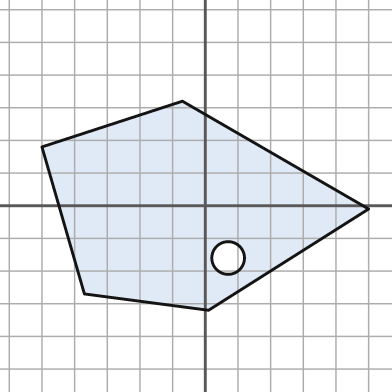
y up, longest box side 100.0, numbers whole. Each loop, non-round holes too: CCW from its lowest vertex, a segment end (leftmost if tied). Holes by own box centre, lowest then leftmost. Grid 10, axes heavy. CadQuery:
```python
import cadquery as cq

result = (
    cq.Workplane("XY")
    .moveTo(1.0, -32.0)
    .lineTo(50.0, -1.0)
    .lineTo(-7.0, 32.0)
    .lineTo(-50.0, 18.0)
    .lineTo(-37.0, -27.0)
    .close()
    .moveTo(7.0, -16.0)
    .circle(5.0)
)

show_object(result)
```